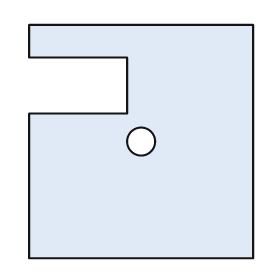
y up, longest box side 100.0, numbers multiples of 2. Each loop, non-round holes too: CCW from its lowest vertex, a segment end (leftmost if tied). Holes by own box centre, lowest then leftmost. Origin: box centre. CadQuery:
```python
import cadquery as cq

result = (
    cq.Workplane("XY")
    .moveTo(-48.0, -50.0)
    .lineTo(48.0, -50.0)
    .lineTo(48.0, 50.0)
    .lineTo(-48.0, 50.0)
    .lineTo(-48.0, 36.0)
    .lineTo(-6.0, 36.0)
    .lineTo(-6.0, 12.0)
    .lineTo(-48.0, 12.0)
    .close()
    .moveTo(0.0, 0.0)
    .circle(6.0)
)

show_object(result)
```